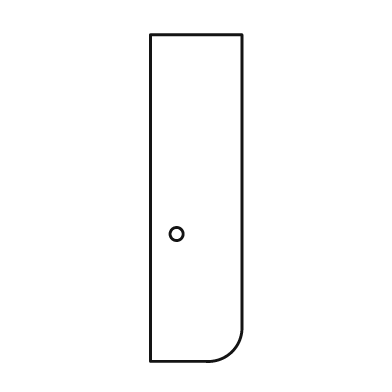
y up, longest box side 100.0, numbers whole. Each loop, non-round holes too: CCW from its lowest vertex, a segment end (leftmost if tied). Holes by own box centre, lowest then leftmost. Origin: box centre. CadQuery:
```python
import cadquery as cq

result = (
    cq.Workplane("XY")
    .moveTo(-14.0, -50.0)
    .lineTo(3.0, -50.0)
    .threePointArc((11.0, -47.0), (14.0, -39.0))
    .lineTo(14.0, 50.0)
    .lineTo(-14.0, 50.0)
    .close()
    .moveTo(-6.0, -11.0)
    .circle(2.0)
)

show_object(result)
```